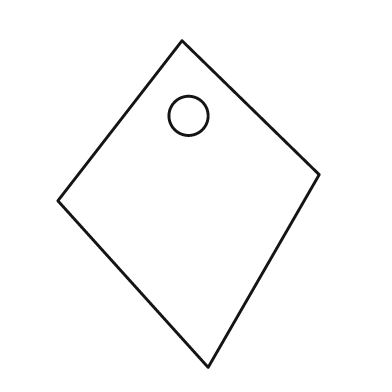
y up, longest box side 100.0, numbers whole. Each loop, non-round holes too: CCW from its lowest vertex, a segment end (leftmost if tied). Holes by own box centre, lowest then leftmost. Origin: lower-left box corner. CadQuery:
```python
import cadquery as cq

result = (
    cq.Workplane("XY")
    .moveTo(46.0, 0.0)
    .lineTo(80.0, 59.0)
    .lineTo(38.0, 100.0)
    .lineTo(0.0, 51.0)
    .close()
    .moveTo(40.0, 77.0)
    .circle(6.0)
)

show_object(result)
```